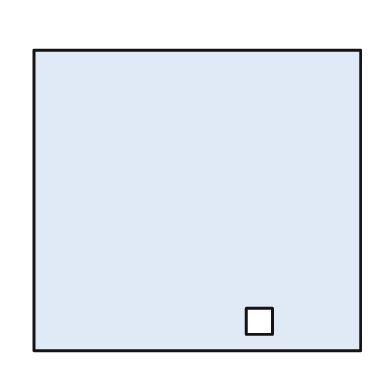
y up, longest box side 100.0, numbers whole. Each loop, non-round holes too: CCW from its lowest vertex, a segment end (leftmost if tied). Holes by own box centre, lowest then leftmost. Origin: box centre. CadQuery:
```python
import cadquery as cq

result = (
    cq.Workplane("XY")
    .moveTo(-50.0, -46.0)
    .lineTo(50.0, -46.0)
    .lineTo(50.0, 46.0)
    .lineTo(-50.0, 46.0)
    .close()
    .moveTo(15.0, -41.0)
    .lineTo(23.0, -41.0)
    .lineTo(23.0, -33.0)
    .lineTo(15.0, -33.0)
    .close()
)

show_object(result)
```